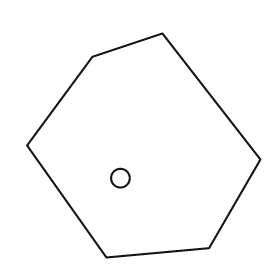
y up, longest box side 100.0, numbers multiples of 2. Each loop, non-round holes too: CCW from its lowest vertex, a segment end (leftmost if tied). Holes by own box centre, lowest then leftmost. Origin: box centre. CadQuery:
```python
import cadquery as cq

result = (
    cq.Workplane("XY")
    .moveTo(-16.0, -48.0)
    .lineTo(28.0, -44.0)
    .lineTo(50.0, -6.0)
    .lineTo(8.0, 48.0)
    .lineTo(-22.0, 38.0)
    .lineTo(-50.0, 0.0)
    .close()
    .moveTo(-10.0, -14.0)
    .circle(4.0)
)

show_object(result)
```